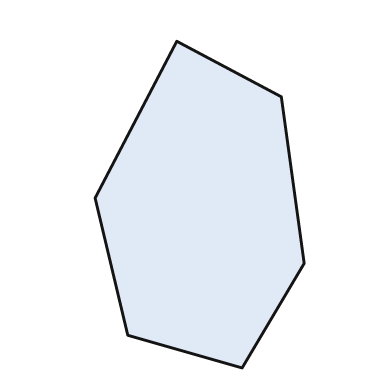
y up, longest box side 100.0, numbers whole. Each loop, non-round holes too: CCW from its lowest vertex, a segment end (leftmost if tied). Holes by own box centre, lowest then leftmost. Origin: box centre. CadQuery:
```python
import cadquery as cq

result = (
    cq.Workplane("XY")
    .moveTo(13.0, -50.0)
    .lineTo(32.0, -18.0)
    .lineTo(25.0, 33.0)
    .lineTo(-7.0, 50.0)
    .lineTo(-32.0, 2.0)
    .lineTo(-22.0, -40.0)
    .close()
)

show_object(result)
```